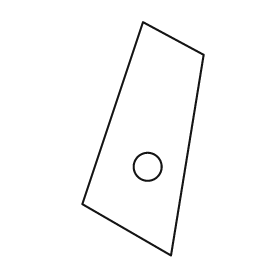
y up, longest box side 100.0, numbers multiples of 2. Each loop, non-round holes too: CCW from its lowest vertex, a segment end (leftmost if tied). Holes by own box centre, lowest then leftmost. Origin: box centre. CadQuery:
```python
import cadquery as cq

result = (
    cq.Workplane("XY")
    .moveTo(12.0, -50.0)
    .lineTo(26.0, 36.0)
    .lineTo(0.0, 50.0)
    .lineTo(-26.0, -28.0)
    .close()
    .moveTo(2.0, -12.0)
    .circle(6.0)
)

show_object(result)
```